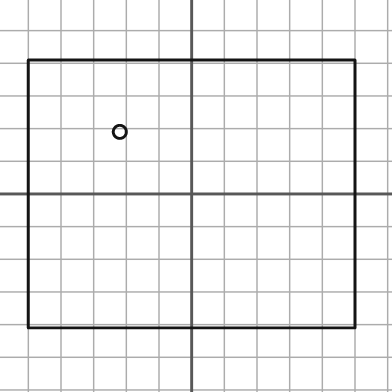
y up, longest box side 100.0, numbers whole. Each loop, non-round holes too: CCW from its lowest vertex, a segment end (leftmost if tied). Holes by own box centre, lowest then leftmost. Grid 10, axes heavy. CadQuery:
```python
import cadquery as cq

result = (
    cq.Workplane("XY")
    .moveTo(-50.0, -41.0)
    .lineTo(50.0, -41.0)
    .lineTo(50.0, 41.0)
    .lineTo(-50.0, 41.0)
    .close()
    .moveTo(-22.0, 19.0)
    .circle(2.0)
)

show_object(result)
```